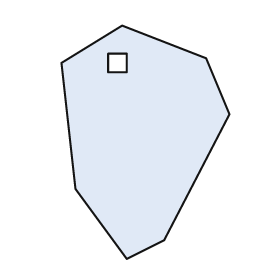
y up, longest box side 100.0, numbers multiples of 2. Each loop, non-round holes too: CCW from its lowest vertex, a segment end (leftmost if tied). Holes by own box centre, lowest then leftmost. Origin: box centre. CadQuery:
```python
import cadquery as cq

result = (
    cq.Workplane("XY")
    .moveTo(-8.0, -50.0)
    .lineTo(8.0, -42.0)
    .lineTo(36.0, 12.0)
    .lineTo(26.0, 36.0)
    .lineTo(-10.0, 50.0)
    .lineTo(-36.0, 34.0)
    .lineTo(-30.0, -20.0)
    .close()
    .moveTo(-16.0, 30.0)
    .lineTo(-8.0, 30.0)
    .lineTo(-8.0, 38.0)
    .lineTo(-16.0, 38.0)
    .close()
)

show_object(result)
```